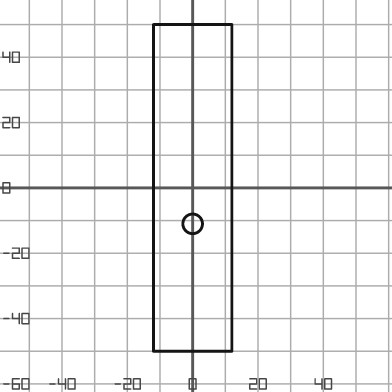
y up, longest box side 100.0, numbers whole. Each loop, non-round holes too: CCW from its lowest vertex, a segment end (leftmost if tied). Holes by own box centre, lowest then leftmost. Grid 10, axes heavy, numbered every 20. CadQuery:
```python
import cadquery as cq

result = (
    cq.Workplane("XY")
    .moveTo(-12.0, -50.0)
    .lineTo(12.0, -50.0)
    .lineTo(12.0, 50.0)
    .lineTo(-12.0, 50.0)
    .close()
    .moveTo(0.0, -11.0)
    .circle(3.0)
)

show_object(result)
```